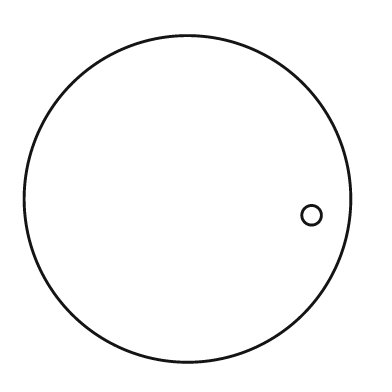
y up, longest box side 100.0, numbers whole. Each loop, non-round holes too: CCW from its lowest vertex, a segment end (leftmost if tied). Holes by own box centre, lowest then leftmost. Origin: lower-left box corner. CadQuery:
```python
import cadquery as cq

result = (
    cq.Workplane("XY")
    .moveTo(50.0, 50.0)
    .circle(50.0)
    .moveTo(88.0, 45.0)
    .circle(3.0)
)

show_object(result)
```